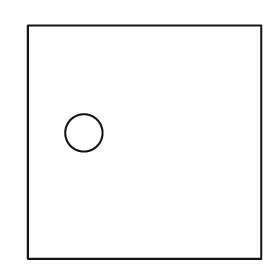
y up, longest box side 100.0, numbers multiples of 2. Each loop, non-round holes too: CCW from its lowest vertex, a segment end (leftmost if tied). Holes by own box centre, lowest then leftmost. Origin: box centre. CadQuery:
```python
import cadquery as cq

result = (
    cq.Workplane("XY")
    .moveTo(-50.0, -50.0)
    .lineTo(50.0, -50.0)
    .lineTo(50.0, 50.0)
    .lineTo(-50.0, 50.0)
    .close()
    .moveTo(-26.0, 4.0)
    .circle(8.0)
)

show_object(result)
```